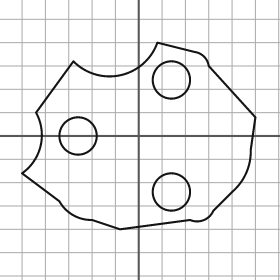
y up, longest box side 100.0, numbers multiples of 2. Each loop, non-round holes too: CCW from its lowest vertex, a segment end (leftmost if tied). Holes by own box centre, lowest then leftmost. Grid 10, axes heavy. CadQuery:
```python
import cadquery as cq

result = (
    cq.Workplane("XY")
    .moveTo(-8.0, -40.0)
    .lineTo(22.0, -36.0)
    .threePointArc((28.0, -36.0), (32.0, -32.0))
    .lineTo(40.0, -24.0)
    .threePointArc((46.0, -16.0), (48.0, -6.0))
    .lineTo(50.0, 8.0)
    .lineTo(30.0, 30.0)
    .threePointArc((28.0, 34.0), (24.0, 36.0))
    .lineTo(8.0, 40.0)
    .threePointArc((-8.0, 26.0), (-28.0, 32.0))
    .lineTo(-44.0, 10.0)
    .threePointArc((-42.0, -4.0), (-50.0, -16.0))
    .lineTo(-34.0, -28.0)
    .threePointArc((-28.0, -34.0), (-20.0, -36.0))
    .close()
    .moveTo(14.0, -24.0)
    .circle(8.0)
    .moveTo(-26.0, 0.0)
    .circle(8.0)
    .moveTo(14.0, 24.0)
    .circle(8.0)
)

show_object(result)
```